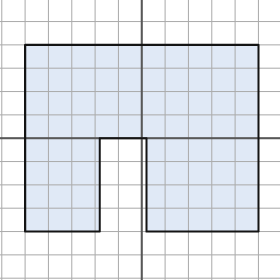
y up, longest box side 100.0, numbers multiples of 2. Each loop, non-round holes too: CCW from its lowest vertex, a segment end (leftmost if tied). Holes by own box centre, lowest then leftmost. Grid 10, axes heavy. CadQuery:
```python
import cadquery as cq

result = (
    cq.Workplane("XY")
    .moveTo(-50.0, -40.0)
    .lineTo(-18.0, -40.0)
    .lineTo(-18.0, 0.0)
    .lineTo(2.0, 0.0)
    .lineTo(2.0, -40.0)
    .lineTo(50.0, -40.0)
    .lineTo(50.0, 40.0)
    .lineTo(-50.0, 40.0)
    .close()
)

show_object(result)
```